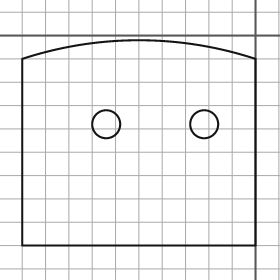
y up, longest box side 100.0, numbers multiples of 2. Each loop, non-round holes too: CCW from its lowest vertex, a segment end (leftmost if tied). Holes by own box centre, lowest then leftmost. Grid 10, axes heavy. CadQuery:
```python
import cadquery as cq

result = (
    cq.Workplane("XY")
    .moveTo(-100.0, -90.0)
    .lineTo(0.0, -90.0)
    .lineTo(0.0, -10.0)
    .threePointArc((-50.0, -2.0), (-100.0, -10.0))
    .close()
    .moveTo(-64.0, -38.0)
    .circle(6.0)
    .moveTo(-22.0, -38.0)
    .circle(6.0)
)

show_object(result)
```